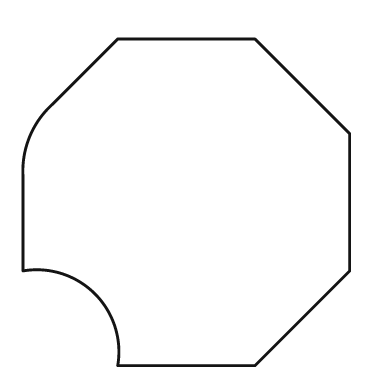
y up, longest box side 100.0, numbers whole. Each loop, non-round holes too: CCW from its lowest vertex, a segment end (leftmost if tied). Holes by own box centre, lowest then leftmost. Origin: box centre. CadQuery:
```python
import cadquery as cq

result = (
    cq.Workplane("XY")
    .moveTo(-21.0, -50.0)
    .lineTo(21.0, -50.0)
    .lineTo(50.0, -21.0)
    .lineTo(50.0, 21.0)
    .lineTo(21.0, 50.0)
    .lineTo(-21.0, 50.0)
    .lineTo(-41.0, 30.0)
    .threePointArc((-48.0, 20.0), (-50.0, 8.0))
    .lineTo(-50.0, -21.0)
    .threePointArc((-28.0, -28.0), (-21.0, -50.0))
    .close()
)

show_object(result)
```